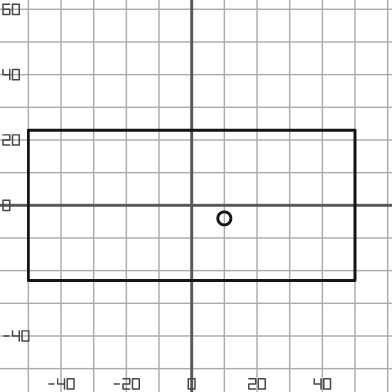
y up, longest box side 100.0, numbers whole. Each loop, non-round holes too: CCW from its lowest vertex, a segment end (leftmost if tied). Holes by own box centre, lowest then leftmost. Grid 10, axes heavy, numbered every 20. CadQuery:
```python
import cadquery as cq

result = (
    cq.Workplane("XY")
    .moveTo(-50.0, -23.0)
    .lineTo(50.0, -23.0)
    .lineTo(50.0, 23.0)
    .lineTo(-50.0, 23.0)
    .close()
    .moveTo(10.0, -4.0)
    .circle(2.0)
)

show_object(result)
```